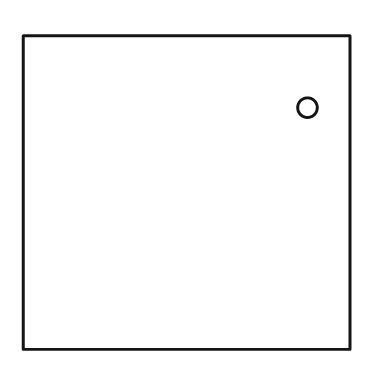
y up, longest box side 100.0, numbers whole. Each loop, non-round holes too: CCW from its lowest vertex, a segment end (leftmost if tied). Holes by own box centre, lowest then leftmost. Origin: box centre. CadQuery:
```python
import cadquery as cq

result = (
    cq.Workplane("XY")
    .moveTo(-50.0, -48.0)
    .lineTo(50.0, -48.0)
    .lineTo(50.0, 48.0)
    .lineTo(-50.0, 48.0)
    .close()
    .moveTo(37.0, 26.0)
    .circle(3.0)
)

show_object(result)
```